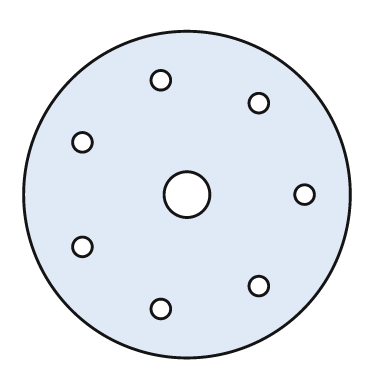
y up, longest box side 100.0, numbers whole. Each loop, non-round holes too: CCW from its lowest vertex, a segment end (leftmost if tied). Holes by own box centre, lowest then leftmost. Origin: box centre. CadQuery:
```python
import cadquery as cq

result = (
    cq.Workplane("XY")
    .moveTo(0.0, 0.0)
    .circle(50.0)
    .moveTo(-8.0, -35.0)
    .circle(3.0)
    .moveTo(22.0, -28.0)
    .circle(3.0)
    .moveTo(-32.0, -16.0)
    .circle(3.0)
    .moveTo(0.0, 0.0)
    .circle(7.0)
    .moveTo(36.0, 0.0)
    .circle(3.0)
    .moveTo(-32.0, 16.0)
    .circle(3.0)
    .moveTo(22.0, 28.0)
    .circle(3.0)
    .moveTo(-8.0, 35.0)
    .circle(3.0)
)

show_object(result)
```